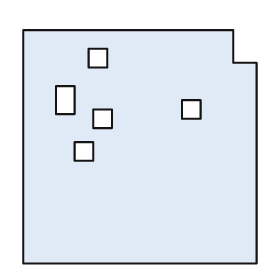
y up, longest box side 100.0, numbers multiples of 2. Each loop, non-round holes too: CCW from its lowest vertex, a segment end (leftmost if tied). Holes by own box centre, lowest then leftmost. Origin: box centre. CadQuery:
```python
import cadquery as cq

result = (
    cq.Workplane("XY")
    .moveTo(-50.0, -50.0)
    .lineTo(50.0, -50.0)
    .lineTo(50.0, 36.0)
    .lineTo(40.0, 36.0)
    .lineTo(40.0, 50.0)
    .lineTo(-50.0, 50.0)
    .close()
    .moveTo(-28.0, -6.0)
    .lineTo(-20.0, -6.0)
    .lineTo(-20.0, 2.0)
    .lineTo(-28.0, 2.0)
    .close()
    .moveTo(-20.0, 8.0)
    .lineTo(-12.0, 8.0)
    .lineTo(-12.0, 16.0)
    .lineTo(-20.0, 16.0)
    .close()
    .moveTo(18.0, 12.0)
    .lineTo(26.0, 12.0)
    .lineTo(26.0, 20.0)
    .lineTo(18.0, 20.0)
    .close()
    .moveTo(-36.0, 14.0)
    .lineTo(-28.0, 14.0)
    .lineTo(-28.0, 26.0)
    .lineTo(-36.0, 26.0)
    .close()
    .moveTo(-22.0, 34.0)
    .lineTo(-14.0, 34.0)
    .lineTo(-14.0, 42.0)
    .lineTo(-22.0, 42.0)
    .close()
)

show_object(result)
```